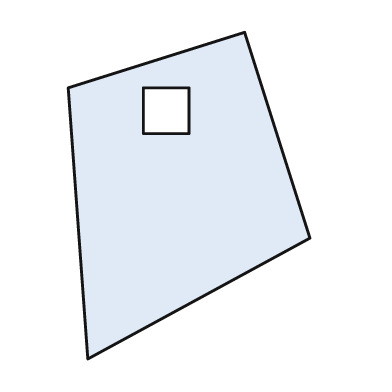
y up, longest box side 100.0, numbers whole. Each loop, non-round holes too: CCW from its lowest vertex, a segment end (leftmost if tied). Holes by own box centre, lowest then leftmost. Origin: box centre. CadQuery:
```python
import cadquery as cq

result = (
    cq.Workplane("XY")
    .moveTo(-31.0, -50.0)
    .lineTo(37.0, -13.0)
    .lineTo(17.0, 50.0)
    .lineTo(-37.0, 33.0)
    .close()
    .moveTo(-14.0, 19.0)
    .lineTo(0.0, 19.0)
    .lineTo(0.0, 33.0)
    .lineTo(-14.0, 33.0)
    .close()
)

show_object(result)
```